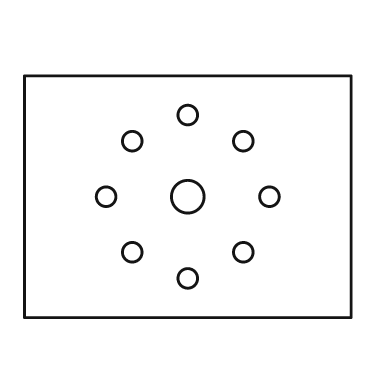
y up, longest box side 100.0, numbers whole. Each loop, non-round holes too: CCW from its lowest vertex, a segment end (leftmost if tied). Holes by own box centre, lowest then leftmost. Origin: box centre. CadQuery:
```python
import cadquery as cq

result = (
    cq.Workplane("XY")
    .moveTo(-50.0, -37.0)
    .lineTo(50.0, -37.0)
    .lineTo(50.0, 37.0)
    .lineTo(-50.0, 37.0)
    .close()
    .moveTo(0.0, -25.0)
    .circle(3.0)
    .moveTo(-17.0, -17.0)
    .circle(3.0)
    .moveTo(17.0, -17.0)
    .circle(3.0)
    .moveTo(-25.0, 0.0)
    .circle(3.0)
    .moveTo(0.0, 0.0)
    .circle(5.0)
    .moveTo(25.0, 0.0)
    .circle(3.0)
    .moveTo(-17.0, 17.0)
    .circle(3.0)
    .moveTo(17.0, 17.0)
    .circle(3.0)
    .moveTo(0.0, 25.0)
    .circle(3.0)
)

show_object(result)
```